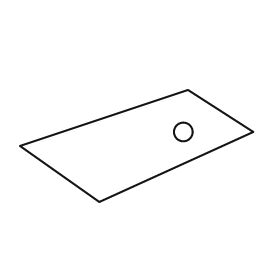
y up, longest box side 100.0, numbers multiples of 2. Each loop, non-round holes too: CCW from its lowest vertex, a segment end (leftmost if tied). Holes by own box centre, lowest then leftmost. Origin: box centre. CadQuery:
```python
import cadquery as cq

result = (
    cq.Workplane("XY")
    .moveTo(-16.0, -24.0)
    .lineTo(50.0, 6.0)
    .lineTo(22.0, 24.0)
    .lineTo(-50.0, 0.0)
    .close()
    .moveTo(20.0, 6.0)
    .circle(4.0)
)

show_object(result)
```